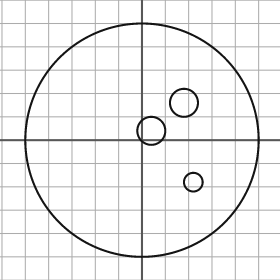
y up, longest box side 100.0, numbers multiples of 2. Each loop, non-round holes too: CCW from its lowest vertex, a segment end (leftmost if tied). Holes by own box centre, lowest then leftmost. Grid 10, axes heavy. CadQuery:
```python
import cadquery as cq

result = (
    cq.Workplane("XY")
    .moveTo(0.0, 0.0)
    .circle(50.0)
    .moveTo(22.0, -18.0)
    .circle(4.0)
    .moveTo(4.0, 4.0)
    .circle(6.0)
    .moveTo(18.0, 16.0)
    .circle(6.0)
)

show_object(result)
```